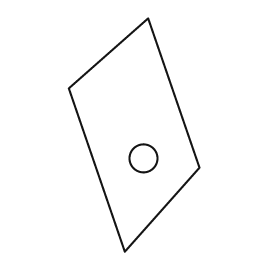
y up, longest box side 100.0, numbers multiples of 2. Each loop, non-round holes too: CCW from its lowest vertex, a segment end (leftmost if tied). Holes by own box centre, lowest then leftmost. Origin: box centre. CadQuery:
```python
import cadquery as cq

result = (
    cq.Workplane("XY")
    .moveTo(-4.0, -50.0)
    .lineTo(28.0, -14.0)
    .lineTo(6.0, 50.0)
    .lineTo(-28.0, 20.0)
    .close()
    .moveTo(4.0, -10.0)
    .circle(6.0)
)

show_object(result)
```